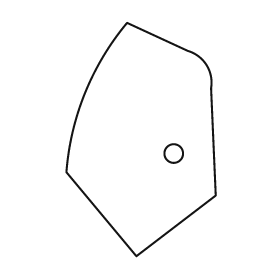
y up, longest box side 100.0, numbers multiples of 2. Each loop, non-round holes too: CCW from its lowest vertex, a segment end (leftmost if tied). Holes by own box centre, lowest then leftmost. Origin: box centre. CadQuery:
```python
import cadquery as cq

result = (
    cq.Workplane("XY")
    .moveTo(-2.0, -50.0)
    .lineTo(32.0, -24.0)
    .lineTo(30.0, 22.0)
    .threePointArc((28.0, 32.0), (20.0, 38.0))
    .lineTo(-6.0, 50.0)
    .threePointArc((-24.0, 20.0), (-32.0, -14.0))
    .close()
    .moveTo(14.0, -6.0)
    .circle(4.0)
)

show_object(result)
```